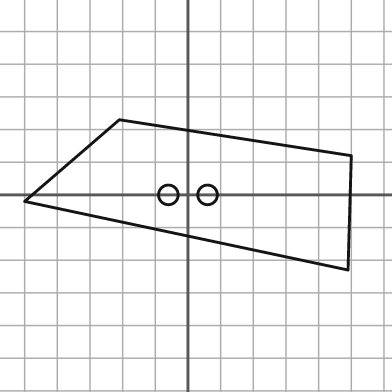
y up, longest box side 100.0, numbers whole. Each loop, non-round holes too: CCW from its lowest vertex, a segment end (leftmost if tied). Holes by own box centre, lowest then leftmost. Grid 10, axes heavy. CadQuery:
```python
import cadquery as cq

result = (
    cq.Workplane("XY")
    .moveTo(49.0, -23.0)
    .lineTo(50.0, 12.0)
    .lineTo(-21.0, 23.0)
    .lineTo(-50.0, -2.0)
    .close()
    .moveTo(-6.0, 0.0)
    .circle(3.0)
    .moveTo(6.0, 0.0)
    .circle(3.0)
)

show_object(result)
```